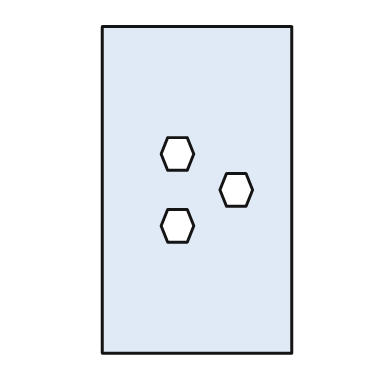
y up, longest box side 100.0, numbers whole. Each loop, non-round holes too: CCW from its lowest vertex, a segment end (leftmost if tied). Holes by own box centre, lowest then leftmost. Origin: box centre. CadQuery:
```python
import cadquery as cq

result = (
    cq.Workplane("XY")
    .moveTo(-29.0, -50.0)
    .lineTo(29.0, -50.0)
    .lineTo(29.0, 50.0)
    .lineTo(-29.0, 50.0)
    .close()
    .moveTo(-9.0, -16.0)
    .lineTo(-3.0, -16.0)
    .lineTo(-1.0, -11.0)
    .lineTo(-3.0, -6.0)
    .lineTo(-9.0, -6.0)
    .lineTo(-11.0, -11.0)
    .close()
    .moveTo(9.0, -5.0)
    .lineTo(15.0, -5.0)
    .lineTo(17.0, 0.0)
    .lineTo(15.0, 5.0)
    .lineTo(9.0, 5.0)
    .lineTo(7.0, 0.0)
    .close()
    .moveTo(-9.0, 6.0)
    .lineTo(-3.0, 6.0)
    .lineTo(-1.0, 11.0)
    .lineTo(-3.0, 16.0)
    .lineTo(-9.0, 16.0)
    .lineTo(-11.0, 11.0)
    .close()
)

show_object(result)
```